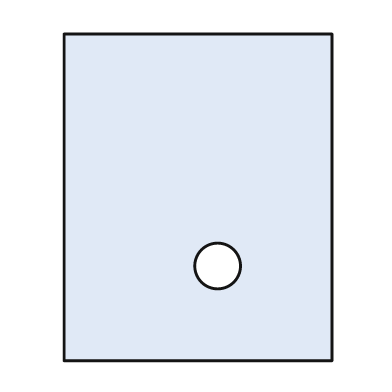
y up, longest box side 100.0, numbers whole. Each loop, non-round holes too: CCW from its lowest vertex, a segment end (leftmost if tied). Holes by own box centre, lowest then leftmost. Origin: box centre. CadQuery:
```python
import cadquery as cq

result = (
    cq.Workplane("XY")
    .moveTo(-41.0, -50.0)
    .lineTo(41.0, -50.0)
    .lineTo(41.0, 50.0)
    .lineTo(-41.0, 50.0)
    .close()
    .moveTo(6.0, -21.0)
    .circle(7.0)
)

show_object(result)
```